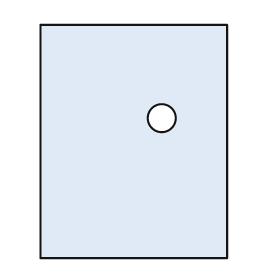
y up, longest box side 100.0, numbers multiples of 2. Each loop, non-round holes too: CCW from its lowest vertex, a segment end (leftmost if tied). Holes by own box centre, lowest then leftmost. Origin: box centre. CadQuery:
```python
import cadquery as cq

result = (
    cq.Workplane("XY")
    .moveTo(-40.0, -50.0)
    .lineTo(40.0, -50.0)
    .lineTo(40.0, 50.0)
    .lineTo(-40.0, 50.0)
    .close()
    .moveTo(12.0, 10.0)
    .circle(6.0)
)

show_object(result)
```